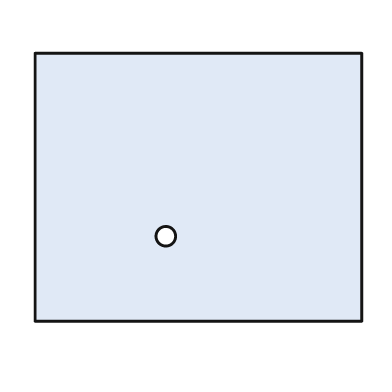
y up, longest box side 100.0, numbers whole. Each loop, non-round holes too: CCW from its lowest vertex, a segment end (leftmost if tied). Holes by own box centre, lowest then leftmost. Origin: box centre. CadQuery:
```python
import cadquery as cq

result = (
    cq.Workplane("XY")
    .moveTo(-50.0, -41.0)
    .lineTo(50.0, -41.0)
    .lineTo(50.0, 41.0)
    .lineTo(-50.0, 41.0)
    .close()
    .moveTo(-10.0, -15.0)
    .circle(3.0)
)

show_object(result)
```